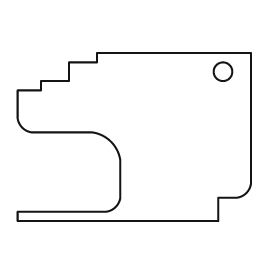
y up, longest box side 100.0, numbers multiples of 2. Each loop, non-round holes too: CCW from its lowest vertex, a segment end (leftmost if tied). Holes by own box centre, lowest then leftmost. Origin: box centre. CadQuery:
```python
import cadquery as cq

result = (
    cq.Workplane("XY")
    .moveTo(-50.0, -36.0)
    .lineTo(36.0, -36.0)
    .lineTo(36.0, -26.0)
    .lineTo(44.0, -26.0)
    .threePointArc((48.0, -24.0), (50.0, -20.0))
    .lineTo(50.0, 36.0)
    .lineTo(-16.0, 36.0)
    .lineTo(-16.0, 32.0)
    .lineTo(-28.0, 32.0)
    .lineTo(-28.0, 24.0)
    .lineTo(-40.0, 24.0)
    .lineTo(-40.0, 20.0)
    .lineTo(-50.0, 20.0)
    .lineTo(-50.0, 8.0)
    .threePointArc((-48.0, 4.0), (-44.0, 2.0))
    .lineTo(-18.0, 2.0)
    .threePointArc((-10.0, -2.0), (-6.0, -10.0))
    .lineTo(-6.0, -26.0)
    .threePointArc((-8.0, -30.0), (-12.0, -32.0))
    .lineTo(-50.0, -32.0)
    .close()
    .moveTo(38.0, 28.0)
    .circle(4.0)
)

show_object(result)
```